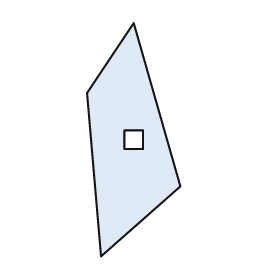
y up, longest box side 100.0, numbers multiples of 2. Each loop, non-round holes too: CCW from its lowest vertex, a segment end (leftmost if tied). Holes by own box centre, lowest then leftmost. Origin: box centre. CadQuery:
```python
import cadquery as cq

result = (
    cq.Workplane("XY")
    .moveTo(-14.0, -50.0)
    .lineTo(20.0, -20.0)
    .lineTo(0.0, 50.0)
    .lineTo(-20.0, 20.0)
    .close()
    .moveTo(-4.0, -4.0)
    .lineTo(4.0, -4.0)
    .lineTo(4.0, 4.0)
    .lineTo(-4.0, 4.0)
    .close()
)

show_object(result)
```